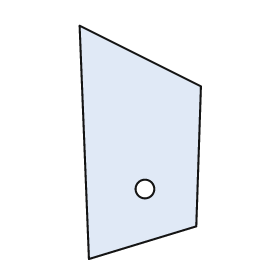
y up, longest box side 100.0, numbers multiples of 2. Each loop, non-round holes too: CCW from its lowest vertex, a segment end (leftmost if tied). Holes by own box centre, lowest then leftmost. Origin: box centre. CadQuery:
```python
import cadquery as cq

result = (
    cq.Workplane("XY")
    .moveTo(-22.0, -50.0)
    .lineTo(24.0, -36.0)
    .lineTo(26.0, 24.0)
    .lineTo(-26.0, 50.0)
    .close()
    .moveTo(2.0, -20.0)
    .circle(4.0)
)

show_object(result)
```